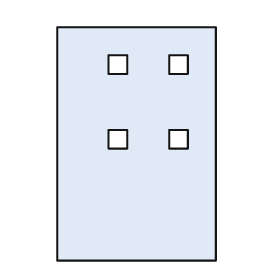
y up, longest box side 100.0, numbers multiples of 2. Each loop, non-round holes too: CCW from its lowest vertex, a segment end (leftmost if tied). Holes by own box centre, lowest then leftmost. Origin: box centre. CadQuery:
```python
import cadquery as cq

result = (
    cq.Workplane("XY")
    .moveTo(-34.0, -50.0)
    .lineTo(34.0, -50.0)
    .lineTo(34.0, 50.0)
    .lineTo(-34.0, 50.0)
    .close()
    .moveTo(-12.0, -2.0)
    .lineTo(-4.0, -2.0)
    .lineTo(-4.0, 6.0)
    .lineTo(-12.0, 6.0)
    .close()
    .moveTo(14.0, -2.0)
    .lineTo(22.0, -2.0)
    .lineTo(22.0, 6.0)
    .lineTo(14.0, 6.0)
    .close()
    .moveTo(-12.0, 30.0)
    .lineTo(-4.0, 30.0)
    .lineTo(-4.0, 38.0)
    .lineTo(-12.0, 38.0)
    .close()
    .moveTo(14.0, 30.0)
    .lineTo(22.0, 30.0)
    .lineTo(22.0, 38.0)
    .lineTo(14.0, 38.0)
    .close()
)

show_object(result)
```